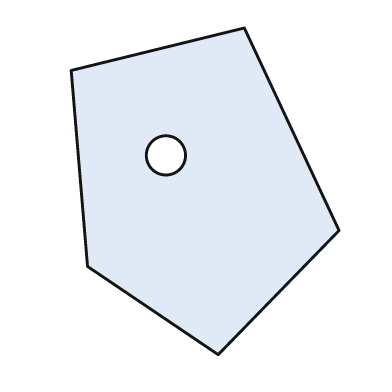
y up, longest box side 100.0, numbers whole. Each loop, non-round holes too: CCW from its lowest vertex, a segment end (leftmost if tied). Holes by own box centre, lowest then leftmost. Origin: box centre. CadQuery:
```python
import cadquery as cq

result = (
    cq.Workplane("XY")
    .moveTo(4.0, -50.0)
    .lineTo(41.0, -12.0)
    .lineTo(12.0, 50.0)
    .lineTo(-41.0, 37.0)
    .lineTo(-36.0, -23.0)
    .close()
    .moveTo(-12.0, 11.0)
    .circle(6.0)
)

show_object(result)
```